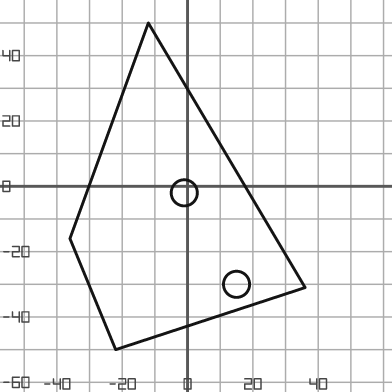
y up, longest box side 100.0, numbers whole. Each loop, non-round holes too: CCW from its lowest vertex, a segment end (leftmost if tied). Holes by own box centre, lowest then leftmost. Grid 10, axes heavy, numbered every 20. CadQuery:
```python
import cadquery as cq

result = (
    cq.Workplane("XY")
    .moveTo(-22.0, -50.0)
    .lineTo(36.0, -31.0)
    .lineTo(-12.0, 50.0)
    .lineTo(-36.0, -16.0)
    .close()
    .moveTo(15.0, -30.0)
    .circle(4.0)
    .moveTo(-1.0, -2.0)
    .circle(4.0)
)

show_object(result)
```